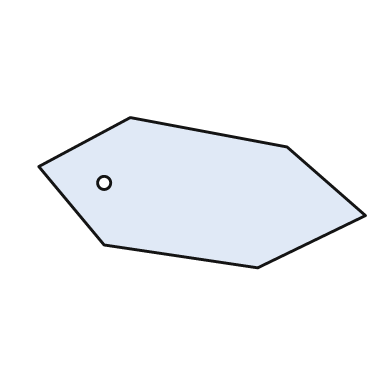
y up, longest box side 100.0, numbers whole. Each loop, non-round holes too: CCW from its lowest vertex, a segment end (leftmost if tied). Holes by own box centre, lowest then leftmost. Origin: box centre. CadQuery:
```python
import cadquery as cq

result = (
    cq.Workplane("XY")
    .moveTo(17.0, -23.0)
    .lineTo(50.0, -7.0)
    .lineTo(26.0, 14.0)
    .lineTo(-22.0, 23.0)
    .lineTo(-50.0, 8.0)
    .lineTo(-30.0, -16.0)
    .close()
    .moveTo(-30.0, 3.0)
    .circle(2.0)
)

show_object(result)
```